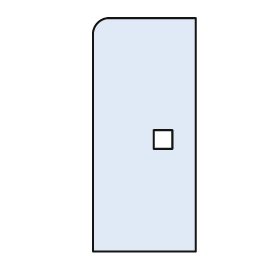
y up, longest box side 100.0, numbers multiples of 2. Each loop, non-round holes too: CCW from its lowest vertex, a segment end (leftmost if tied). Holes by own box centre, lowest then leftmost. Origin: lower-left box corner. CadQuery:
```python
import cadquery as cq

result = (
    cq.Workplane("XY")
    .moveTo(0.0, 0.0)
    .lineTo(44.0, 0.0)
    .lineTo(44.0, 100.0)
    .lineTo(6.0, 100.0)
    .threePointArc((2.0, 98.0), (0.0, 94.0))
    .close()
    .moveTo(26.0, 44.0)
    .lineTo(34.0, 44.0)
    .lineTo(34.0, 52.0)
    .lineTo(26.0, 52.0)
    .close()
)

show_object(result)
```